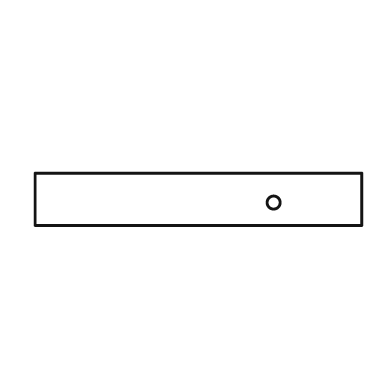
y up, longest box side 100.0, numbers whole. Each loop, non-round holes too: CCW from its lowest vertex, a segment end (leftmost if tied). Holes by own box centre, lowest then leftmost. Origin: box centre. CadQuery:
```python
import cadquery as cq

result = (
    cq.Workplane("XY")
    .moveTo(-50.0, -8.0)
    .lineTo(50.0, -8.0)
    .lineTo(50.0, 8.0)
    .lineTo(-50.0, 8.0)
    .close()
    .moveTo(23.0, -1.0)
    .circle(2.0)
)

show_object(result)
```